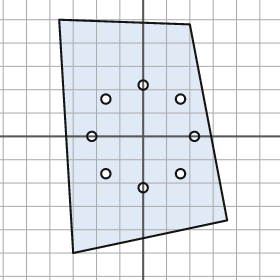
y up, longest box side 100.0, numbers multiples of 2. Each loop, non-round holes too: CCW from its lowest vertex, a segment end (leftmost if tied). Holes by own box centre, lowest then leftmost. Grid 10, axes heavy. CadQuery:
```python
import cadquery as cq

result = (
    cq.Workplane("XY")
    .moveTo(-30.0, -50.0)
    .lineTo(36.0, -36.0)
    .lineTo(20.0, 48.0)
    .lineTo(-36.0, 50.0)
    .close()
    .moveTo(0.0, -22.0)
    .circle(2.0)
    .moveTo(-16.0, -16.0)
    .circle(2.0)
    .moveTo(16.0, -16.0)
    .circle(2.0)
    .moveTo(-22.0, 0.0)
    .circle(2.0)
    .moveTo(22.0, 0.0)
    .circle(2.0)
    .moveTo(-16.0, 16.0)
    .circle(2.0)
    .moveTo(16.0, 16.0)
    .circle(2.0)
    .moveTo(0.0, 22.0)
    .circle(2.0)
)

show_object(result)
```